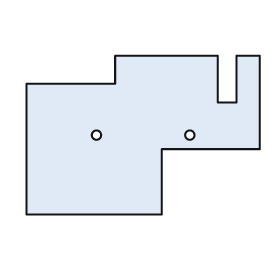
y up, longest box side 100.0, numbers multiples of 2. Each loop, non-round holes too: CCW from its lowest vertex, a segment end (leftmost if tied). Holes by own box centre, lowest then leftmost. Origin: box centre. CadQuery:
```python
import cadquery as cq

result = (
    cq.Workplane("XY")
    .moveTo(-50.0, -34.0)
    .lineTo(8.0, -34.0)
    .lineTo(8.0, -6.0)
    .lineTo(50.0, -6.0)
    .lineTo(50.0, 34.0)
    .lineTo(40.0, 34.0)
    .lineTo(40.0, 14.0)
    .lineTo(32.0, 14.0)
    .lineTo(32.0, 34.0)
    .lineTo(-12.0, 34.0)
    .lineTo(-12.0, 22.0)
    .lineTo(-50.0, 22.0)
    .close()
    .moveTo(-20.0, 0.0)
    .circle(2.0)
    .moveTo(20.0, 0.0)
    .circle(2.0)
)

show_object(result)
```